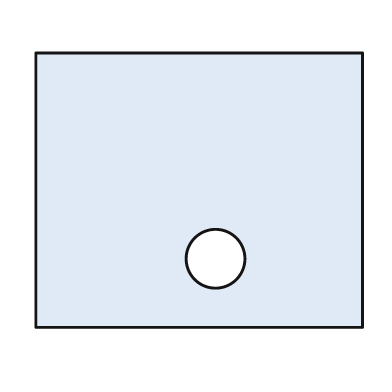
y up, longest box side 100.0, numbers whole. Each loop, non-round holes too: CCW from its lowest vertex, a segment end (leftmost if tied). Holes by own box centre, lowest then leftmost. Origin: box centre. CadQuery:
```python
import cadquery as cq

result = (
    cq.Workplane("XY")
    .moveTo(-50.0, -42.0)
    .lineTo(50.0, -42.0)
    .lineTo(50.0, 42.0)
    .lineTo(-50.0, 42.0)
    .close()
    .moveTo(5.0, -21.0)
    .circle(9.0)
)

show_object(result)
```